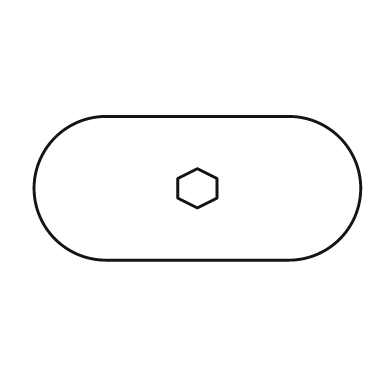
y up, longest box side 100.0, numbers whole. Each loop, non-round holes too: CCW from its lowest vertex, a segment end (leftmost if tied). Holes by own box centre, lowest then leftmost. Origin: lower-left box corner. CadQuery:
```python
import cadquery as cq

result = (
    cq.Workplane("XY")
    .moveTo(22.0, 0.0)
    .lineTo(78.0, 0.0)
    .threePointArc((100.0, 22.0), (78.0, 44.0))
    .lineTo(22.0, 44.0)
    .threePointArc((0.0, 22.0), (22.0, 0.0))
    .close()
    .moveTo(50.0, 16.0)
    .lineTo(56.0, 19.0)
    .lineTo(56.0, 25.0)
    .lineTo(50.0, 28.0)
    .lineTo(44.0, 25.0)
    .lineTo(44.0, 19.0)
    .close()
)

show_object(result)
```